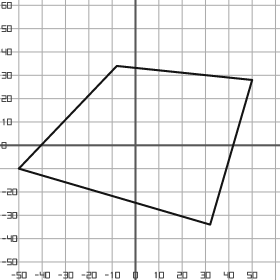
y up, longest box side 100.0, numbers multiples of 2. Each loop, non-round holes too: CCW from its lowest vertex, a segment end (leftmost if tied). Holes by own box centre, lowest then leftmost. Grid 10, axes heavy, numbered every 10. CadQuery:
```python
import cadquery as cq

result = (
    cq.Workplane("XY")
    .moveTo(32.0, -34.0)
    .lineTo(50.0, 28.0)
    .lineTo(-8.0, 34.0)
    .lineTo(-50.0, -10.0)
    .close()
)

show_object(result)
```